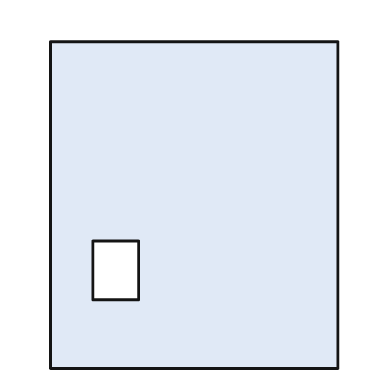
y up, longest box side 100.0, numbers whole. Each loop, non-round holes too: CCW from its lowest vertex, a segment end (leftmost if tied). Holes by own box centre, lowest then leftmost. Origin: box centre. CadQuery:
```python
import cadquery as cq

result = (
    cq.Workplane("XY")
    .moveTo(-44.0, -50.0)
    .lineTo(44.0, -50.0)
    .lineTo(44.0, 50.0)
    .lineTo(-44.0, 50.0)
    .close()
    .moveTo(-31.0, -29.0)
    .lineTo(-17.0, -29.0)
    .lineTo(-17.0, -11.0)
    .lineTo(-31.0, -11.0)
    .close()
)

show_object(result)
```